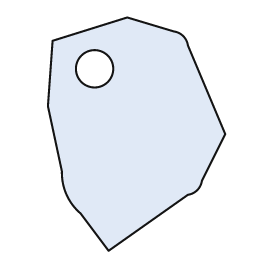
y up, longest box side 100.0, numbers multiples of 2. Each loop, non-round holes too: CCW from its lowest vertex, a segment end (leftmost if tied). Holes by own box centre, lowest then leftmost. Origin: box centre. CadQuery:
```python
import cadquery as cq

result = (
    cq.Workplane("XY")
    .moveTo(-12.0, -50.0)
    .lineTo(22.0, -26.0)
    .threePointArc((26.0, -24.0), (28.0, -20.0))
    .lineTo(38.0, 0.0)
    .lineTo(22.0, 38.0)
    .threePointArc((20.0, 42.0), (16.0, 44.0))
    .lineTo(-4.0, 50.0)
    .lineTo(-36.0, 40.0)
    .lineTo(-38.0, 12.0)
    .lineTo(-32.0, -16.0)
    .threePointArc((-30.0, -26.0), (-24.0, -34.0))
    .close()
    .moveTo(-18.0, 28.0)
    .circle(8.0)
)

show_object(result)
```